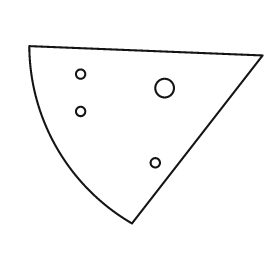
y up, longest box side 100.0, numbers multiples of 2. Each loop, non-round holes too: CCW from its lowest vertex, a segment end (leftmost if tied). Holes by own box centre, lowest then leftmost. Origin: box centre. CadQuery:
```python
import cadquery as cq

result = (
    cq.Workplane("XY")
    .moveTo(-6.0, -38.0)
    .lineTo(50.0, 34.0)
    .lineTo(-50.0, 38.0)
    .threePointArc((-38.0, -6.0), (-6.0, -38.0))
    .close()
    .moveTo(4.0, -12.0)
    .circle(2.0)
    .moveTo(-28.0, 10.0)
    .circle(2.0)
    .moveTo(8.0, 20.0)
    .circle(4.0)
    .moveTo(-28.0, 26.0)
    .circle(2.0)
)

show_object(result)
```